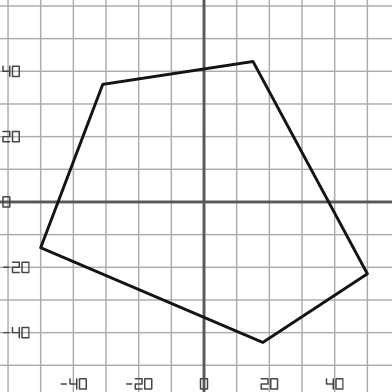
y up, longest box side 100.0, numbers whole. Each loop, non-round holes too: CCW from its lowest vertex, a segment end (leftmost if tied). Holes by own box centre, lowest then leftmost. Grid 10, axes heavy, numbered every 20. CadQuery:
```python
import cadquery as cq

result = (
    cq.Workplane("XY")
    .moveTo(18.0, -43.0)
    .lineTo(50.0, -22.0)
    .lineTo(15.0, 43.0)
    .lineTo(-31.0, 36.0)
    .lineTo(-50.0, -14.0)
    .close()
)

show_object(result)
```